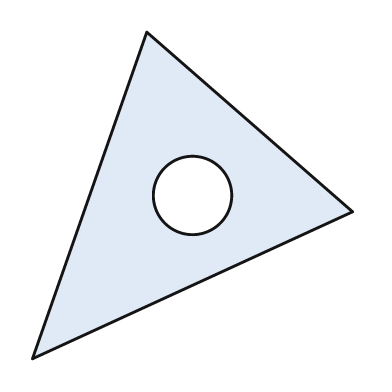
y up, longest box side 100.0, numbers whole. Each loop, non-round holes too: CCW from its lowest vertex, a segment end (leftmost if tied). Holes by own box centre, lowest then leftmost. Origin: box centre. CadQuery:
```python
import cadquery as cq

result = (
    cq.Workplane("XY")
    .moveTo(-49.0, -50.0)
    .lineTo(49.0, -5.0)
    .lineTo(-14.0, 50.0)
    .close()
    .moveTo(0.0, 0.0)
    .circle(12.0)
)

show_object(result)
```